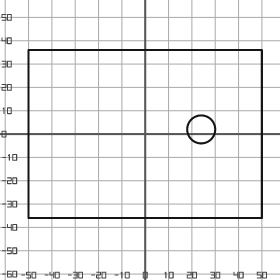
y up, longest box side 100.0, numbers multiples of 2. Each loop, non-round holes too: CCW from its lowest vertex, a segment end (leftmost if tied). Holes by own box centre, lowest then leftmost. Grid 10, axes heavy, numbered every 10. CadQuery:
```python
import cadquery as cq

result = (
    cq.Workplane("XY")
    .moveTo(-50.0, -36.0)
    .lineTo(50.0, -36.0)
    .lineTo(50.0, 36.0)
    .lineTo(-50.0, 36.0)
    .close()
    .moveTo(24.0, 2.0)
    .circle(6.0)
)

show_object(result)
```